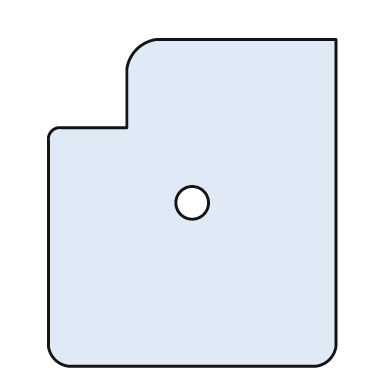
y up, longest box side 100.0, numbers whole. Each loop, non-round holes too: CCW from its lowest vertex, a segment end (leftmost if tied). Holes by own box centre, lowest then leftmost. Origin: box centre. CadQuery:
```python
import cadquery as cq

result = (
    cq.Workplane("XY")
    .moveTo(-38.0, -50.0)
    .lineTo(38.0, -50.0)
    .threePointArc((42.0, -48.0), (44.0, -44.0))
    .lineTo(44.0, 50.0)
    .lineTo(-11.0, 50.0)
    .threePointArc((-17.0, 47.0), (-20.0, 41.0))
    .lineTo(-20.0, 23.0)
    .lineTo(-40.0, 23.0)
    .threePointArc((-43.0, 22.0), (-44.0, 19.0))
    .lineTo(-44.0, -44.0)
    .threePointArc((-42.0, -48.0), (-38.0, -50.0))
    .close()
    .moveTo(0.0, 0.0)
    .circle(5.0)
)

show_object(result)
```